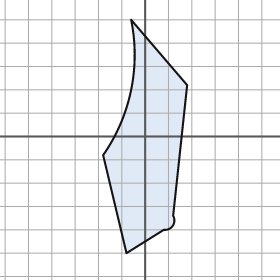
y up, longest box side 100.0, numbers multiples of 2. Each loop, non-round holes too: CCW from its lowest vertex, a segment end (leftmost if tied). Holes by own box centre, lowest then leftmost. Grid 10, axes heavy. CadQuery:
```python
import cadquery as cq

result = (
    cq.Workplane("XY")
    .moveTo(-8.0, -50.0)
    .lineTo(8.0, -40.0)
    .threePointArc((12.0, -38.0), (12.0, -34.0))
    .lineTo(18.0, 22.0)
    .lineTo(-6.0, 50.0)
    .threePointArc((-6.0, 20.0), (-18.0, -8.0))
    .close()
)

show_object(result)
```